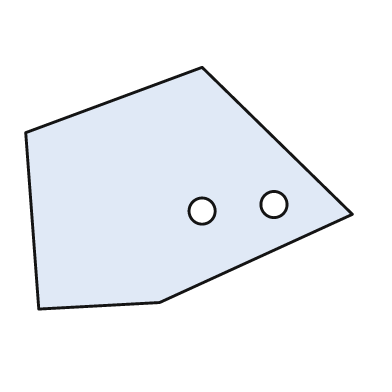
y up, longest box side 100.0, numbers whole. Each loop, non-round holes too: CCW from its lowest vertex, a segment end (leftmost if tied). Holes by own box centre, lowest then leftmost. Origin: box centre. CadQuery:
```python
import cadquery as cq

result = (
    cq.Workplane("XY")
    .moveTo(-46.0, -37.0)
    .lineTo(-9.0, -35.0)
    .lineTo(50.0, -8.0)
    .lineTo(4.0, 37.0)
    .lineTo(-50.0, 17.0)
    .close()
    .moveTo(4.0, -7.0)
    .circle(4.0)
    .moveTo(26.0, -5.0)
    .circle(4.0)
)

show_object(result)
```